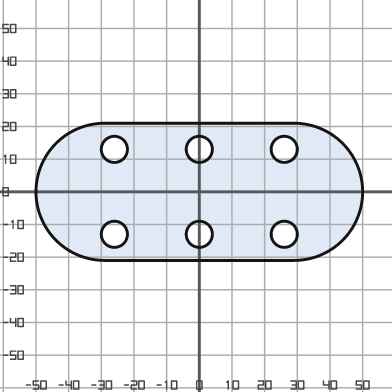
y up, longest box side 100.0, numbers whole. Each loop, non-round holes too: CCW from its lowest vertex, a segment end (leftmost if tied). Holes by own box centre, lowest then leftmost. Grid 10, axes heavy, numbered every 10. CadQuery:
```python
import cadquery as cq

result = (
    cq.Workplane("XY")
    .moveTo(-29.0, -21.0)
    .lineTo(29.0, -21.0)
    .threePointArc((50.0, 0.0), (29.0, 21.0))
    .lineTo(-29.0, 21.0)
    .threePointArc((-50.0, 0.0), (-29.0, -21.0))
    .close()
    .moveTo(-26.0, -13.0)
    .circle(4.0)
    .moveTo(0.0, -13.0)
    .circle(4.0)
    .moveTo(26.0, -13.0)
    .circle(4.0)
    .moveTo(-26.0, 13.0)
    .circle(4.0)
    .moveTo(0.0, 13.0)
    .circle(4.0)
    .moveTo(26.0, 13.0)
    .circle(4.0)
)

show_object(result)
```